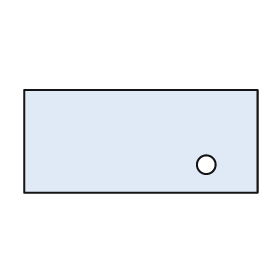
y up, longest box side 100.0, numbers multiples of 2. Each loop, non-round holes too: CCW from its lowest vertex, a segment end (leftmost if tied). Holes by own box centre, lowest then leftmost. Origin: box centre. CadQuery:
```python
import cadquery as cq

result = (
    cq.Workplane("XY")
    .moveTo(-50.0, -22.0)
    .lineTo(50.0, -22.0)
    .lineTo(50.0, 22.0)
    .lineTo(-50.0, 22.0)
    .close()
    .moveTo(28.0, -10.0)
    .circle(4.0)
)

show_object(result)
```